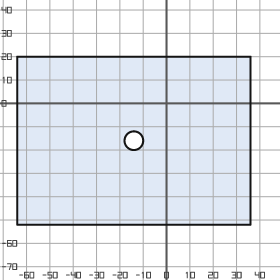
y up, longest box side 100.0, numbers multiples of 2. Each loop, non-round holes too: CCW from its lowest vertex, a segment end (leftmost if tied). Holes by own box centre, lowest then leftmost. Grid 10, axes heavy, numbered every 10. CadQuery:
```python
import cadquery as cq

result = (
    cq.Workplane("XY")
    .moveTo(-64.0, -52.0)
    .lineTo(36.0, -52.0)
    .lineTo(36.0, 20.0)
    .lineTo(-64.0, 20.0)
    .close()
    .moveTo(-14.0, -16.0)
    .circle(4.0)
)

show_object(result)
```